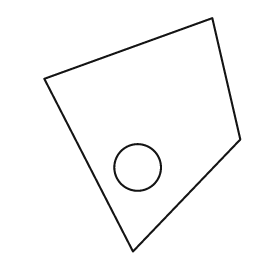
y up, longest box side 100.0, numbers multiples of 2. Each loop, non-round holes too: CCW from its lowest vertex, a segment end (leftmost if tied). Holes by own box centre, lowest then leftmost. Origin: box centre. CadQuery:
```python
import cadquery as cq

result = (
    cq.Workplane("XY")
    .moveTo(-4.0, -50.0)
    .lineTo(42.0, -2.0)
    .lineTo(30.0, 50.0)
    .lineTo(-42.0, 24.0)
    .close()
    .moveTo(-2.0, -14.0)
    .circle(10.0)
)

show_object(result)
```